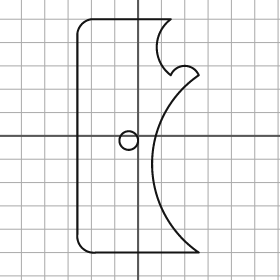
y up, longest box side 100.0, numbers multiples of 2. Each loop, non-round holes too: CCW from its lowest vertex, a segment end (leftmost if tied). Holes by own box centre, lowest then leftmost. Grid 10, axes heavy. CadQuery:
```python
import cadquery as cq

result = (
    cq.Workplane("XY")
    .moveTo(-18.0, -50.0)
    .lineTo(26.0, -50.0)
    .threePointArc((6.0, -12.0), (26.0, 26.0))
    .threePointArc((20.0, 30.0), (14.0, 26.0))
    .threePointArc((8.0, 38.0), (14.0, 50.0))
    .lineTo(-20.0, 50.0)
    .threePointArc((-24.0, 48.0), (-26.0, 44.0))
    .lineTo(-26.0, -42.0)
    .threePointArc((-24.0, -48.0), (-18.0, -50.0))
    .close()
    .moveTo(-4.0, -2.0)
    .circle(4.0)
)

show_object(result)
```